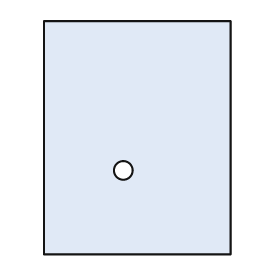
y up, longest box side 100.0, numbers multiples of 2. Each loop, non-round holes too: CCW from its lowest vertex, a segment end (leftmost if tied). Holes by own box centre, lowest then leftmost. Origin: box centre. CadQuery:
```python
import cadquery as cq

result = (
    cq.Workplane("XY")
    .moveTo(-40.0, -50.0)
    .lineTo(40.0, -50.0)
    .lineTo(40.0, 50.0)
    .lineTo(-40.0, 50.0)
    .close()
    .moveTo(-6.0, -14.0)
    .circle(4.0)
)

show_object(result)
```